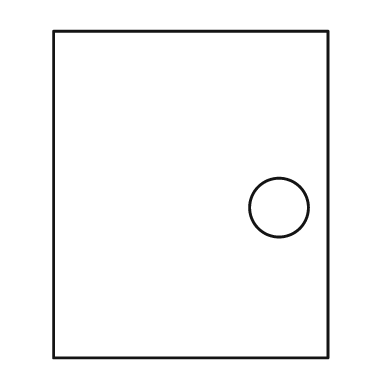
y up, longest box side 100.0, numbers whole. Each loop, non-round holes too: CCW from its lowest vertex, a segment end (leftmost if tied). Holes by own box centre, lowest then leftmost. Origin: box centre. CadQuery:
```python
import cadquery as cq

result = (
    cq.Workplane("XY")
    .moveTo(-42.0, -50.0)
    .lineTo(42.0, -50.0)
    .lineTo(42.0, 50.0)
    .lineTo(-42.0, 50.0)
    .close()
    .moveTo(27.0, -4.0)
    .circle(9.0)
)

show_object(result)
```